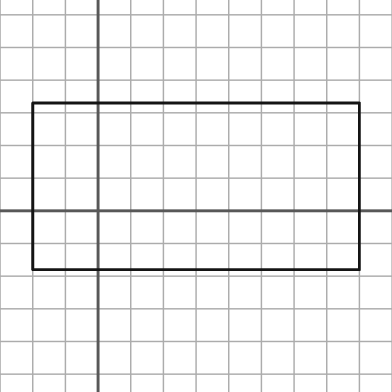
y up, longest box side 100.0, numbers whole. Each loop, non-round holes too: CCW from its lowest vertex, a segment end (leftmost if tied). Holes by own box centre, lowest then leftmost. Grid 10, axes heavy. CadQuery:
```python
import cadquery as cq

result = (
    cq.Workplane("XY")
    .moveTo(-20.0, -18.0)
    .lineTo(80.0, -18.0)
    .lineTo(80.0, 33.0)
    .lineTo(-20.0, 33.0)
    .close()
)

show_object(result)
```